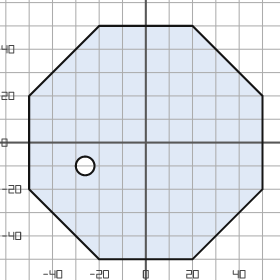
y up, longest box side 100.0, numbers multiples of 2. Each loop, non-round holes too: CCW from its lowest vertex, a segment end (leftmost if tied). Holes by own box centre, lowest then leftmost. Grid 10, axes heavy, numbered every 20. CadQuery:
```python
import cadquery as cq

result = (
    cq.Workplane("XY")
    .moveTo(-20.0, -50.0)
    .lineTo(20.0, -50.0)
    .lineTo(50.0, -20.0)
    .lineTo(50.0, 20.0)
    .lineTo(20.0, 50.0)
    .lineTo(-20.0, 50.0)
    .lineTo(-50.0, 20.0)
    .lineTo(-50.0, -20.0)
    .close()
    .moveTo(-26.0, -10.0)
    .circle(4.0)
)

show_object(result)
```